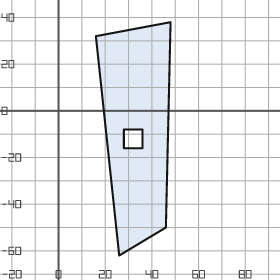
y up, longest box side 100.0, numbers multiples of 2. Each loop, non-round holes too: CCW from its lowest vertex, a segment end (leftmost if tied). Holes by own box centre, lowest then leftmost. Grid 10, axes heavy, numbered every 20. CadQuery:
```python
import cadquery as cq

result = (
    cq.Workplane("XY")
    .moveTo(26.0, -62.0)
    .lineTo(46.0, -50.0)
    .lineTo(48.0, 38.0)
    .lineTo(16.0, 32.0)
    .close()
    .moveTo(28.0, -16.0)
    .lineTo(36.0, -16.0)
    .lineTo(36.0, -8.0)
    .lineTo(28.0, -8.0)
    .close()
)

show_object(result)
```